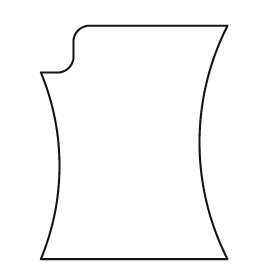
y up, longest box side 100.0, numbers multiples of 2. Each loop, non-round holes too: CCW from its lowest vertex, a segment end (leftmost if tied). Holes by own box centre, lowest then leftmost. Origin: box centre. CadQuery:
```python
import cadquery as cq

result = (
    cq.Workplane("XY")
    .moveTo(-40.0, -50.0)
    .lineTo(40.0, -50.0)
    .threePointArc((28.0, 0.0), (40.0, 50.0))
    .lineTo(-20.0, 50.0)
    .threePointArc((-24.0, 48.0), (-26.0, 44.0))
    .lineTo(-26.0, 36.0)
    .threePointArc((-28.0, 32.0), (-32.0, 30.0))
    .lineTo(-40.0, 30.0)
    .threePointArc((-32.0, -10.0), (-40.0, -50.0))
    .close()
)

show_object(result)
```